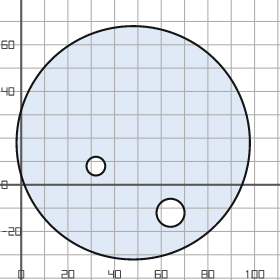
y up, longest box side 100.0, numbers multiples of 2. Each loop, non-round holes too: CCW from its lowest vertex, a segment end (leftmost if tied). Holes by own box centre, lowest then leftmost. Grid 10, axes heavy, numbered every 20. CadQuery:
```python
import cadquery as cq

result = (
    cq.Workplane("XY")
    .moveTo(48.0, 18.0)
    .circle(50.0)
    .moveTo(64.0, -12.0)
    .circle(6.0)
    .moveTo(32.0, 8.0)
    .circle(4.0)
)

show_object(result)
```